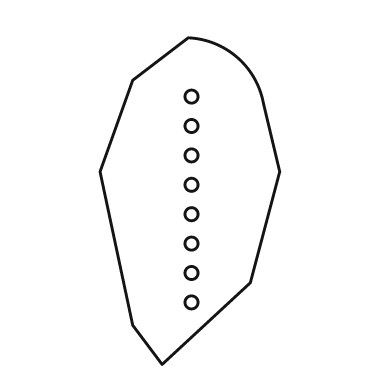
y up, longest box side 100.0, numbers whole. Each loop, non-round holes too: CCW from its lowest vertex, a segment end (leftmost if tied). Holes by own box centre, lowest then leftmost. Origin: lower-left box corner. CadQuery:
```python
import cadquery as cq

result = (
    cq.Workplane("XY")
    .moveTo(19.0, 0.0)
    .lineTo(46.0, 25.0)
    .lineTo(55.0, 59.0)
    .lineTo(50.0, 80.0)
    .threePointArc((42.0, 94.0), (27.0, 100.0))
    .lineTo(10.0, 87.0)
    .lineTo(0.0, 59.0)
    .lineTo(10.0, 12.0)
    .close()
    .moveTo(28.0, 19.0)
    .circle(2.0)
    .moveTo(28.0, 28.0)
    .circle(2.0)
    .moveTo(28.0, 37.0)
    .circle(2.0)
    .moveTo(28.0, 46.0)
    .circle(2.0)
    .moveTo(28.0, 55.0)
    .circle(2.0)
    .moveTo(28.0, 64.0)
    .circle(2.0)
    .moveTo(28.0, 73.0)
    .circle(2.0)
    .moveTo(28.0, 82.0)
    .circle(2.0)
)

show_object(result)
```